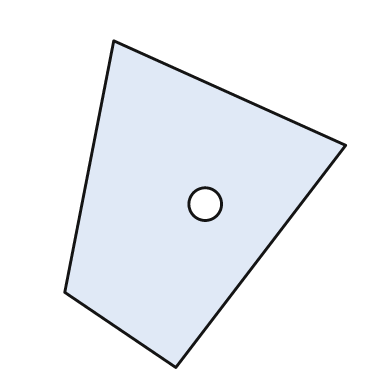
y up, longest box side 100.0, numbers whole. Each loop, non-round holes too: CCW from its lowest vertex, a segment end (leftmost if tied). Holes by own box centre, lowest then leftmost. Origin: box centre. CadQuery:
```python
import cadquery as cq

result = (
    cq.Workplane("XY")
    .moveTo(-9.0, -50.0)
    .lineTo(43.0, 18.0)
    .lineTo(-28.0, 50.0)
    .lineTo(-43.0, -27.0)
    .close()
    .moveTo(0.0, 0.0)
    .circle(5.0)
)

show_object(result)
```